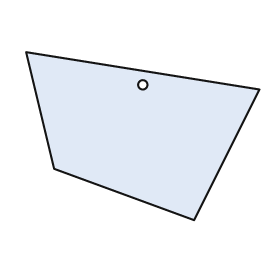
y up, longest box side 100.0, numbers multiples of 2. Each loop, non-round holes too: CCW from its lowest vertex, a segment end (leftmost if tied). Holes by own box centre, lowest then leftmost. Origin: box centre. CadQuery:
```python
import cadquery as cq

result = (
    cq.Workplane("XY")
    .moveTo(22.0, -36.0)
    .lineTo(50.0, 20.0)
    .lineTo(-50.0, 36.0)
    .lineTo(-38.0, -14.0)
    .close()
    .moveTo(0.0, 22.0)
    .circle(2.0)
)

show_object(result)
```